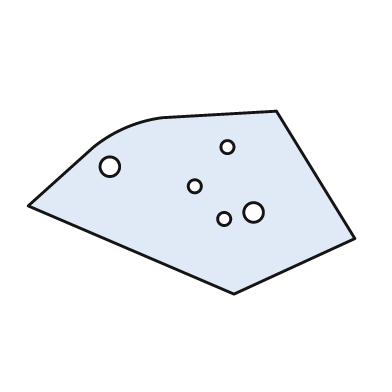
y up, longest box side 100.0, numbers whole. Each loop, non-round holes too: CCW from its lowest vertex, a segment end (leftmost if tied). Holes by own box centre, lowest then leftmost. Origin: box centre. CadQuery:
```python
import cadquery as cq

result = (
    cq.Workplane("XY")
    .moveTo(13.0, -28.0)
    .lineTo(50.0, -11.0)
    .lineTo(26.0, 28.0)
    .lineTo(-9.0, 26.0)
    .threePointArc((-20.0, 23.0), (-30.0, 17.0))
    .lineTo(-50.0, -1.0)
    .close()
    .moveTo(10.0, -5.0)
    .circle(2.0)
    .moveTo(19.0, -3.0)
    .circle(3.0)
    .moveTo(1.0, 5.0)
    .circle(2.0)
    .moveTo(-25.0, 11.0)
    .circle(3.0)
    .moveTo(11.0, 17.0)
    .circle(2.0)
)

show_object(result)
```